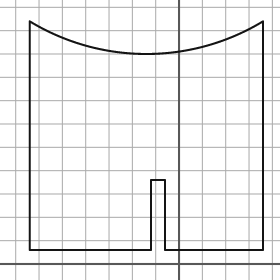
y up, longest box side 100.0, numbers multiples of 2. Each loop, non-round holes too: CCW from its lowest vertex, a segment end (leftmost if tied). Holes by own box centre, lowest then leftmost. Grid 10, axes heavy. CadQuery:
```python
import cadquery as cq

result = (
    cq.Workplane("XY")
    .moveTo(-64.0, 6.0)
    .lineTo(-12.0, 6.0)
    .lineTo(-12.0, 36.0)
    .lineTo(-6.0, 36.0)
    .lineTo(-6.0, 6.0)
    .lineTo(36.0, 6.0)
    .lineTo(36.0, 104.0)
    .threePointArc((-14.0, 90.0), (-64.0, 104.0))
    .close()
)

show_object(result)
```